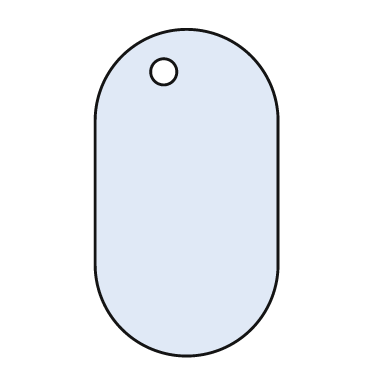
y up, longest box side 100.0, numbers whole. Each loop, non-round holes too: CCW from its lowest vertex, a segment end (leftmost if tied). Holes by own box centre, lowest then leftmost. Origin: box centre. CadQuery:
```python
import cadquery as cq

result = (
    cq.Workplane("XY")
    .moveTo(-28.0, -22.0)
    .threePointArc((0.0, -50.0), (28.0, -22.0))
    .lineTo(28.0, 22.0)
    .threePointArc((0.0, 50.0), (-28.0, 22.0))
    .close()
    .moveTo(-7.0, 37.0)
    .circle(4.0)
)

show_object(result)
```